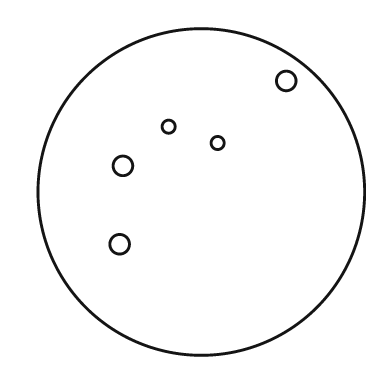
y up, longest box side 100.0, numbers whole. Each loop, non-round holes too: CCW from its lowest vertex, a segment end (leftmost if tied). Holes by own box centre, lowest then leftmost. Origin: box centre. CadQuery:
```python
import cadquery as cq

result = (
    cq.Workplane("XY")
    .moveTo(0.0, 0.0)
    .circle(50.0)
    .moveTo(-25.0, -16.0)
    .circle(3.0)
    .moveTo(-24.0, 8.0)
    .circle(3.0)
    .moveTo(5.0, 15.0)
    .circle(2.0)
    .moveTo(-10.0, 20.0)
    .circle(2.0)
    .moveTo(26.0, 34.0)
    .circle(3.0)
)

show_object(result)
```